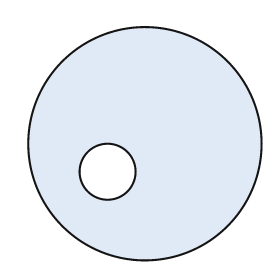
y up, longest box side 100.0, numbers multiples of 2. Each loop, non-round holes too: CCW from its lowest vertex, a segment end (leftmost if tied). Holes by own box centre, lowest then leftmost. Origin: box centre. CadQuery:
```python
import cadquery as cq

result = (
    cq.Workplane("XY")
    .moveTo(0.0, 0.0)
    .circle(50.0)
    .moveTo(-16.0, -12.0)
    .circle(12.0)
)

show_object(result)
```